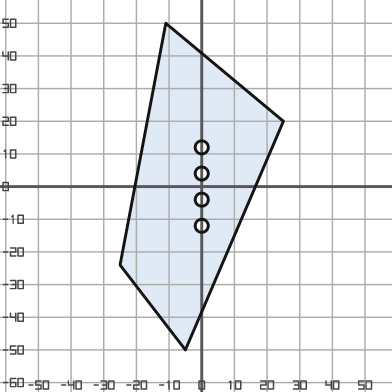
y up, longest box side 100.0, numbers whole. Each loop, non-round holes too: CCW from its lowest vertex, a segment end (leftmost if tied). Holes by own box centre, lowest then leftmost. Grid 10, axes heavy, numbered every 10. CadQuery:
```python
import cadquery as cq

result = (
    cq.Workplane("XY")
    .moveTo(-5.0, -50.0)
    .lineTo(25.0, 20.0)
    .lineTo(-11.0, 50.0)
    .lineTo(-25.0, -24.0)
    .close()
    .moveTo(0.0, -12.0)
    .circle(2.0)
    .moveTo(0.0, -4.0)
    .circle(2.0)
    .moveTo(0.0, 4.0)
    .circle(2.0)
    .moveTo(0.0, 12.0)
    .circle(2.0)
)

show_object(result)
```